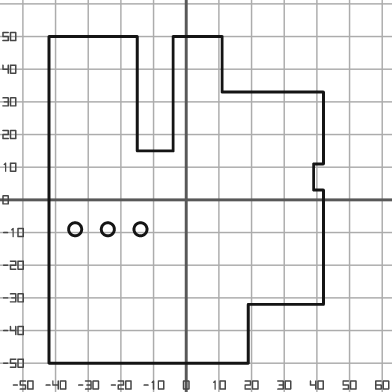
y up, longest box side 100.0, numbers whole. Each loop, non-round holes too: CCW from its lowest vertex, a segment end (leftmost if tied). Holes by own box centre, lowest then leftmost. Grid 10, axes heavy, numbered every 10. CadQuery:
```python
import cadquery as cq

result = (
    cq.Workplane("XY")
    .moveTo(-42.0, -50.0)
    .lineTo(19.0, -50.0)
    .lineTo(19.0, -32.0)
    .lineTo(42.0, -32.0)
    .lineTo(42.0, 3.0)
    .lineTo(39.0, 3.0)
    .lineTo(39.0, 11.0)
    .lineTo(42.0, 11.0)
    .lineTo(42.0, 33.0)
    .lineTo(11.0, 33.0)
    .lineTo(11.0, 50.0)
    .lineTo(-4.0, 50.0)
    .lineTo(-4.0, 15.0)
    .lineTo(-15.0, 15.0)
    .lineTo(-15.0, 50.0)
    .lineTo(-42.0, 50.0)
    .close()
    .moveTo(-34.0, -9.0)
    .circle(2.0)
    .moveTo(-24.0, -9.0)
    .circle(2.0)
    .moveTo(-14.0, -9.0)
    .circle(2.0)
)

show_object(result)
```